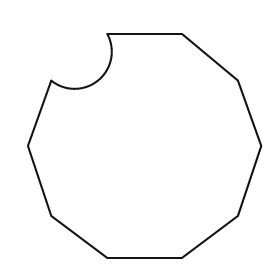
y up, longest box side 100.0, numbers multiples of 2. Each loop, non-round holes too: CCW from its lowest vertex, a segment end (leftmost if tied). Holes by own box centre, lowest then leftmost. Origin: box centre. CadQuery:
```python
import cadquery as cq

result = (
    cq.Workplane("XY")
    .moveTo(-16.0, -48.0)
    .lineTo(16.0, -48.0)
    .lineTo(40.0, -30.0)
    .lineTo(50.0, 0.0)
    .lineTo(40.0, 28.0)
    .lineTo(16.0, 48.0)
    .lineTo(-16.0, 48.0)
    .threePointArc((-20.0, 28.0), (-40.0, 28.0))
    .lineTo(-50.0, 0.0)
    .lineTo(-40.0, -30.0)
    .close()
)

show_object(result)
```